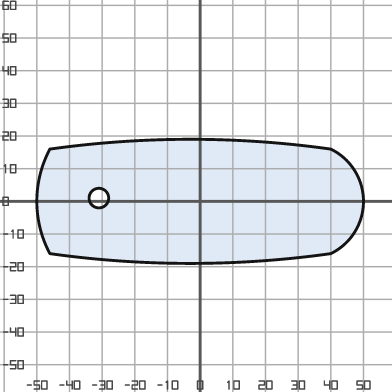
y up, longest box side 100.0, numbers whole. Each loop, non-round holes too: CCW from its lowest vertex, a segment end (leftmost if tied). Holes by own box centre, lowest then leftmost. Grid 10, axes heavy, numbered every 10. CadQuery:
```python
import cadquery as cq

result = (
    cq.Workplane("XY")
    .moveTo(-46.0, -16.0)
    .threePointArc((-3.0, -19.0), (40.0, -16.0))
    .threePointArc((50.0, 0.0), (40.0, 16.0))
    .threePointArc((-3.0, 19.0), (-46.0, 16.0))
    .threePointArc((-50.0, 0.0), (-46.0, -16.0))
    .close()
    .moveTo(-31.0, 1.0)
    .circle(3.0)
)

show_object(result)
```